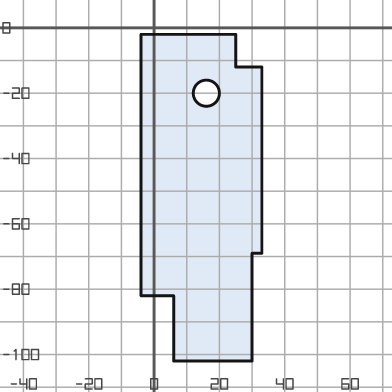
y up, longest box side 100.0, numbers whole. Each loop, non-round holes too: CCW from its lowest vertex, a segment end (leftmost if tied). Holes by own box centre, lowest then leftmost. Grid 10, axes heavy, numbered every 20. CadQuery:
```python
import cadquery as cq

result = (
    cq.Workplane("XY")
    .moveTo(6.0, -102.0)
    .lineTo(30.0, -102.0)
    .lineTo(30.0, -69.0)
    .lineTo(33.0, -69.0)
    .lineTo(33.0, -12.0)
    .lineTo(25.0, -12.0)
    .lineTo(25.0, -2.0)
    .lineTo(-4.0, -2.0)
    .lineTo(-4.0, -82.0)
    .lineTo(6.0, -82.0)
    .close()
    .moveTo(16.0, -20.0)
    .circle(4.0)
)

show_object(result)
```